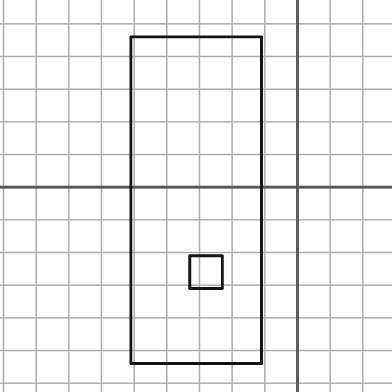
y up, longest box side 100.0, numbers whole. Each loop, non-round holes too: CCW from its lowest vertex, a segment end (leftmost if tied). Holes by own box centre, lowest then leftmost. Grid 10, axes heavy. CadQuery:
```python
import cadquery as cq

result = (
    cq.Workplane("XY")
    .moveTo(-51.0, -54.0)
    .lineTo(-11.0, -54.0)
    .lineTo(-11.0, 46.0)
    .lineTo(-51.0, 46.0)
    .close()
    .moveTo(-33.0, -31.0)
    .lineTo(-23.0, -31.0)
    .lineTo(-23.0, -21.0)
    .lineTo(-33.0, -21.0)
    .close()
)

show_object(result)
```